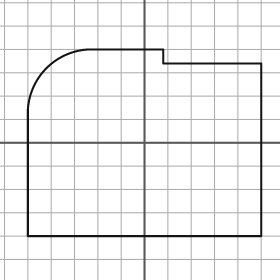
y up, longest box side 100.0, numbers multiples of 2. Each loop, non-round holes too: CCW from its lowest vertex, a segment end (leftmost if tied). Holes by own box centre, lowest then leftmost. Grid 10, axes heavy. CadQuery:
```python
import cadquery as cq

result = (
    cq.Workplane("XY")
    .moveTo(-50.0, -40.0)
    .lineTo(50.0, -40.0)
    .lineTo(50.0, 34.0)
    .lineTo(8.0, 34.0)
    .lineTo(8.0, 40.0)
    .lineTo(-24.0, 40.0)
    .threePointArc((-42.0, 32.0), (-50.0, 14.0))
    .close()
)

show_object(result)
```